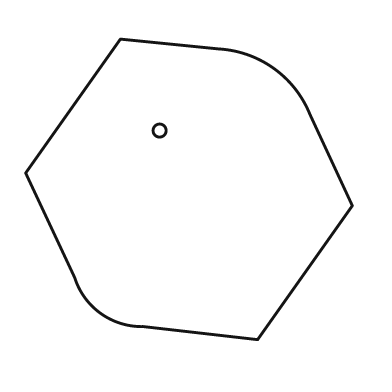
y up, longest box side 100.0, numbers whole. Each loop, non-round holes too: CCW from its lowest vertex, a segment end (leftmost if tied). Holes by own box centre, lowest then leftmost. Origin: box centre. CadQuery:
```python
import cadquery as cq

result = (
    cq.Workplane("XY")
    .moveTo(21.0, -46.0)
    .lineTo(50.0, -5.0)
    .lineTo(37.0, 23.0)
    .threePointArc((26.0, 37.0), (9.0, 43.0))
    .lineTo(-21.0, 46.0)
    .lineTo(-50.0, 5.0)
    .lineTo(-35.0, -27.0)
    .threePointArc((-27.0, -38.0), (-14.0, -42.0))
    .close()
    .moveTo(-9.0, 18.0)
    .circle(2.0)
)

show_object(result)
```